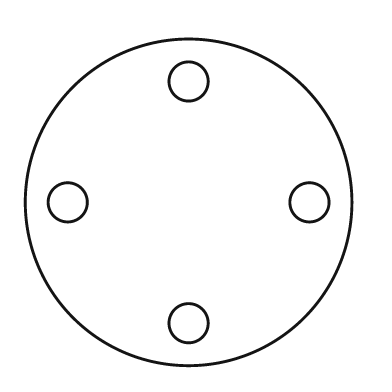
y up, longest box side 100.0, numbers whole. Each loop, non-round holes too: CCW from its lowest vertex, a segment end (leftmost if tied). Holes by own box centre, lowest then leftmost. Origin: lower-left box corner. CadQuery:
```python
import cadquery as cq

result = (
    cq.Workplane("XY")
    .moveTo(50.0, 50.0)
    .circle(50.0)
    .moveTo(50.0, 13.0)
    .circle(6.0)
    .moveTo(13.0, 50.0)
    .circle(6.0)
    .moveTo(87.0, 50.0)
    .circle(6.0)
    .moveTo(50.0, 87.0)
    .circle(6.0)
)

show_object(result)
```